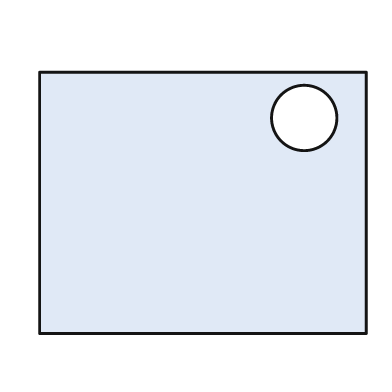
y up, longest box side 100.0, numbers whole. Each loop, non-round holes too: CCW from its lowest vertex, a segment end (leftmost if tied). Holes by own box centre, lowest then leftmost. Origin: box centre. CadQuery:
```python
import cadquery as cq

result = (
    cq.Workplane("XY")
    .moveTo(-50.0, -40.0)
    .lineTo(50.0, -40.0)
    .lineTo(50.0, 40.0)
    .lineTo(-50.0, 40.0)
    .close()
    .moveTo(31.0, 26.0)
    .circle(10.0)
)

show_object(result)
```